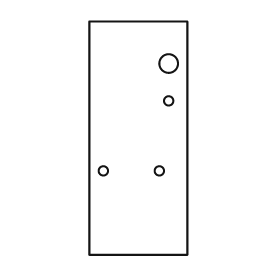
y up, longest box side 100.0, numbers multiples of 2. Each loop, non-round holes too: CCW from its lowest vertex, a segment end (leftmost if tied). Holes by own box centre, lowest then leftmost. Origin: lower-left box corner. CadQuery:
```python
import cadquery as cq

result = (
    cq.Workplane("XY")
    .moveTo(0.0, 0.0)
    .lineTo(42.0, 0.0)
    .lineTo(42.0, 100.0)
    .lineTo(0.0, 100.0)
    .close()
    .moveTo(6.0, 36.0)
    .circle(2.0)
    .moveTo(30.0, 36.0)
    .circle(2.0)
    .moveTo(34.0, 66.0)
    .circle(2.0)
    .moveTo(34.0, 82.0)
    .circle(4.0)
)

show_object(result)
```